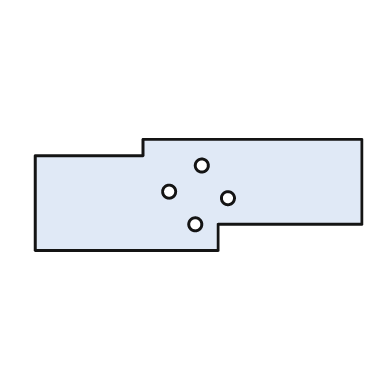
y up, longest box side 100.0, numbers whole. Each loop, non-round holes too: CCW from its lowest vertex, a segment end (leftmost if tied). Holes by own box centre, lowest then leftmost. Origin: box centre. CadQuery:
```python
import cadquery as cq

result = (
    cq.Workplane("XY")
    .moveTo(-50.0, -17.0)
    .lineTo(6.0, -17.0)
    .lineTo(6.0, -9.0)
    .lineTo(50.0, -9.0)
    .lineTo(50.0, 17.0)
    .lineTo(-17.0, 17.0)
    .lineTo(-17.0, 12.0)
    .lineTo(-50.0, 12.0)
    .close()
    .moveTo(-1.0, -9.0)
    .circle(2.0)
    .moveTo(9.0, -1.0)
    .circle(2.0)
    .moveTo(-9.0, 1.0)
    .circle(2.0)
    .moveTo(1.0, 9.0)
    .circle(2.0)
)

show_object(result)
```